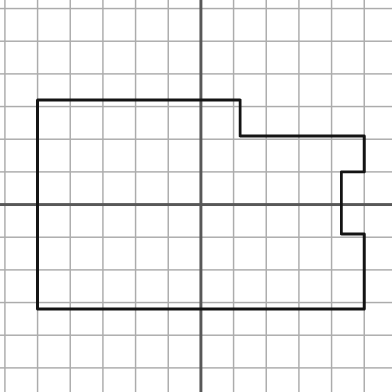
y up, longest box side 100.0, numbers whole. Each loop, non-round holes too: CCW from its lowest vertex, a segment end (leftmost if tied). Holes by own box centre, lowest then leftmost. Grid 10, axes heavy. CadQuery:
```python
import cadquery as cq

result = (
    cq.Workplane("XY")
    .moveTo(-50.0, -32.0)
    .lineTo(50.0, -32.0)
    .lineTo(50.0, -9.0)
    .lineTo(43.0, -9.0)
    .lineTo(43.0, 10.0)
    .lineTo(50.0, 10.0)
    .lineTo(50.0, 21.0)
    .lineTo(12.0, 21.0)
    .lineTo(12.0, 32.0)
    .lineTo(-50.0, 32.0)
    .close()
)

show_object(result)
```